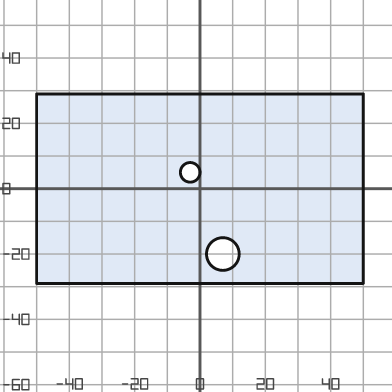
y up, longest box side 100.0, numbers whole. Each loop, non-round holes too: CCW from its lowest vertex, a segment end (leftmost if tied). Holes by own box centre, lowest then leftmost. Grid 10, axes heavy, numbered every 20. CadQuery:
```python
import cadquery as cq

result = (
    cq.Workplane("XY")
    .moveTo(-50.0, -29.0)
    .lineTo(50.0, -29.0)
    .lineTo(50.0, 29.0)
    .lineTo(-50.0, 29.0)
    .close()
    .moveTo(7.0, -20.0)
    .circle(5.0)
    .moveTo(-3.0, 5.0)
    .circle(3.0)
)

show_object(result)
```